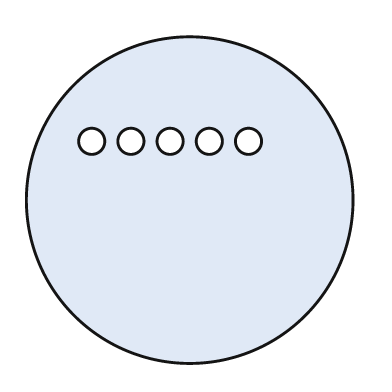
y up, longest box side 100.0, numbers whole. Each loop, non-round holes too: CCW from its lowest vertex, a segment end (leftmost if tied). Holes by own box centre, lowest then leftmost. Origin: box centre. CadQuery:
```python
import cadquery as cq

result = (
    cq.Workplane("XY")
    .moveTo(0.0, 0.0)
    .circle(50.0)
    .moveTo(-30.0, 18.0)
    .circle(4.0)
    .moveTo(-18.0, 18.0)
    .circle(4.0)
    .moveTo(-6.0, 18.0)
    .circle(4.0)
    .moveTo(6.0, 18.0)
    .circle(4.0)
    .moveTo(18.0, 18.0)
    .circle(4.0)
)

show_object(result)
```